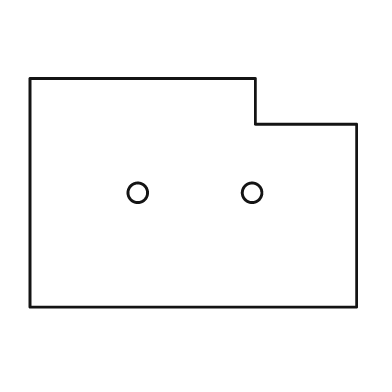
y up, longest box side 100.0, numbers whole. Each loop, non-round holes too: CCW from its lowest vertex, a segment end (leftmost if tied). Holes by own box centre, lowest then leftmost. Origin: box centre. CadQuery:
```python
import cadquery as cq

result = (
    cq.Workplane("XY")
    .moveTo(-50.0, -35.0)
    .lineTo(50.0, -35.0)
    .lineTo(50.0, 21.0)
    .lineTo(19.0, 21.0)
    .lineTo(19.0, 35.0)
    .lineTo(-50.0, 35.0)
    .close()
    .moveTo(-17.0, 0.0)
    .circle(3.0)
    .moveTo(18.0, 0.0)
    .circle(3.0)
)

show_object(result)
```